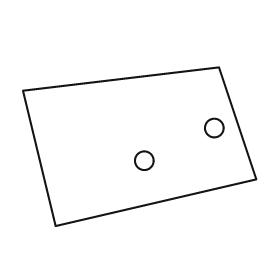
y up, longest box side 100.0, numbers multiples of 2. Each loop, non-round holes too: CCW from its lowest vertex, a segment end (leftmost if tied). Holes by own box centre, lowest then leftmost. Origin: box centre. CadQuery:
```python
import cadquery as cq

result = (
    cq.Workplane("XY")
    .moveTo(-36.0, -34.0)
    .lineTo(50.0, -14.0)
    .lineTo(34.0, 34.0)
    .lineTo(-50.0, 24.0)
    .close()
    .moveTo(2.0, -6.0)
    .circle(4.0)
    .moveTo(32.0, 8.0)
    .circle(4.0)
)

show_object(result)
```